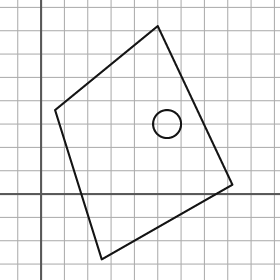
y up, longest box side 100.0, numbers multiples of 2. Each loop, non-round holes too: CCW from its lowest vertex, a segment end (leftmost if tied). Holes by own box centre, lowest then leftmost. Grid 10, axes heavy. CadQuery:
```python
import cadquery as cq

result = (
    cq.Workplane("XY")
    .moveTo(26.0, -28.0)
    .lineTo(82.0, 4.0)
    .lineTo(50.0, 72.0)
    .lineTo(6.0, 36.0)
    .close()
    .moveTo(54.0, 30.0)
    .circle(6.0)
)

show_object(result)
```